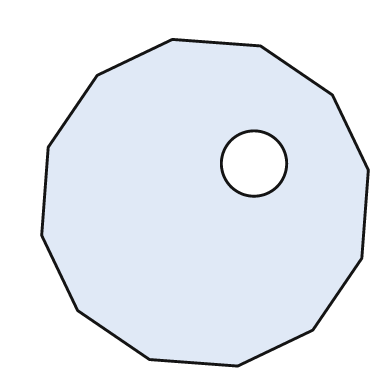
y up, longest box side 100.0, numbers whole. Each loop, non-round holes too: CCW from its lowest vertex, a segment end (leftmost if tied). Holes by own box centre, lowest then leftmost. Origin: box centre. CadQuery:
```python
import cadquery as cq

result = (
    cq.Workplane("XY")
    .moveTo(10.0, -50.0)
    .lineTo(33.0, -39.0)
    .lineTo(48.0, -17.0)
    .lineTo(50.0, 10.0)
    .lineTo(39.0, 33.0)
    .lineTo(17.0, 48.0)
    .lineTo(-10.0, 50.0)
    .lineTo(-33.0, 39.0)
    .lineTo(-48.0, 17.0)
    .lineTo(-50.0, -10.0)
    .lineTo(-39.0, -33.0)
    .lineTo(-17.0, -48.0)
    .close()
    .moveTo(15.0, 12.0)
    .circle(10.0)
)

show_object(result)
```